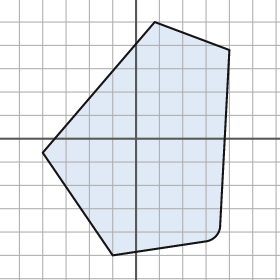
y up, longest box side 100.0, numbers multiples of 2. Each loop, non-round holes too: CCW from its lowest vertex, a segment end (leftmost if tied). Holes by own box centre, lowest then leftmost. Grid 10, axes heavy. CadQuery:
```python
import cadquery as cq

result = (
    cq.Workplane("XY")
    .moveTo(-10.0, -50.0)
    .lineTo(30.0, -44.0)
    .threePointArc((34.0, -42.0), (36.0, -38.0))
    .lineTo(40.0, 38.0)
    .lineTo(8.0, 50.0)
    .lineTo(-40.0, -6.0)
    .close()
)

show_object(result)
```